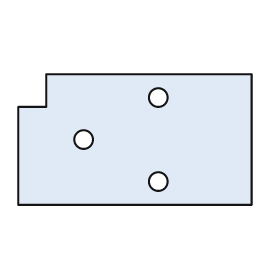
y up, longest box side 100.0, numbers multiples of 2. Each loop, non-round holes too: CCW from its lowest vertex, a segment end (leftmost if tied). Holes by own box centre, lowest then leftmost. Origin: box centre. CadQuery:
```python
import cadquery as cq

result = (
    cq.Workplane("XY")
    .moveTo(-50.0, -28.0)
    .lineTo(50.0, -28.0)
    .lineTo(50.0, 28.0)
    .lineTo(-38.0, 28.0)
    .lineTo(-38.0, 14.0)
    .lineTo(-50.0, 14.0)
    .close()
    .moveTo(10.0, -18.0)
    .circle(4.0)
    .moveTo(-22.0, 0.0)
    .circle(4.0)
    .moveTo(10.0, 18.0)
    .circle(4.0)
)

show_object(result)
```